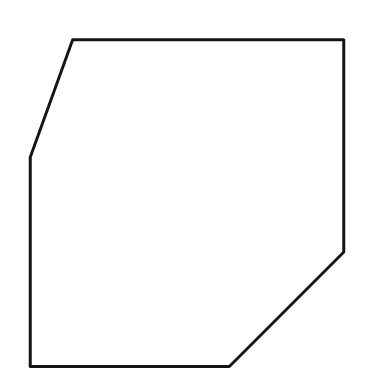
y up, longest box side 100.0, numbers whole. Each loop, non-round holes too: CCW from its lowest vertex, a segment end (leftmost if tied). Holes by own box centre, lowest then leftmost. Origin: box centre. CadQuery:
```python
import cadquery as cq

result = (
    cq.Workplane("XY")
    .moveTo(-48.0, -50.0)
    .lineTo(13.0, -50.0)
    .lineTo(48.0, -15.0)
    .lineTo(48.0, 50.0)
    .lineTo(-35.0, 50.0)
    .lineTo(-48.0, 14.0)
    .close()
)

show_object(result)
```